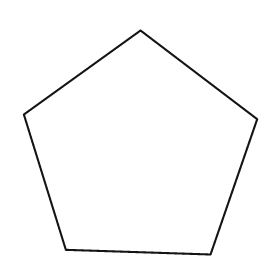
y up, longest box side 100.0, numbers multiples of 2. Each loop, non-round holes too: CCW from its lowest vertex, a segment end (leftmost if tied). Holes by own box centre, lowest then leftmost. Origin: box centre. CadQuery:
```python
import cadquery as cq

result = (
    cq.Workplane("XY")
    .moveTo(30.0, -48.0)
    .lineTo(50.0, 10.0)
    .lineTo(0.0, 48.0)
    .lineTo(-50.0, 12.0)
    .lineTo(-32.0, -46.0)
    .close()
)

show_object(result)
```